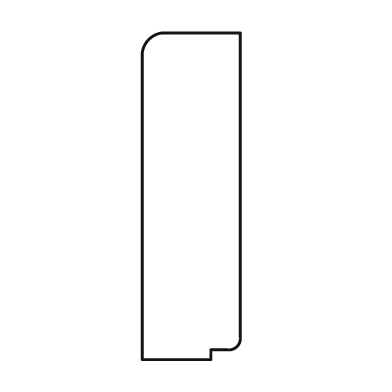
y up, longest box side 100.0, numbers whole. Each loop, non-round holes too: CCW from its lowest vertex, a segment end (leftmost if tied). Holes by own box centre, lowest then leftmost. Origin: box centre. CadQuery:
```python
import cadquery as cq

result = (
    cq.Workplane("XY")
    .moveTo(-15.0, -50.0)
    .lineTo(6.0, -50.0)
    .lineTo(6.0, -47.0)
    .lineTo(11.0, -47.0)
    .threePointArc((14.0, -46.0), (15.0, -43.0))
    .lineTo(15.0, 50.0)
    .lineTo(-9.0, 50.0)
    .threePointArc((-13.0, 48.0), (-15.0, 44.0))
    .close()
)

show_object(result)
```